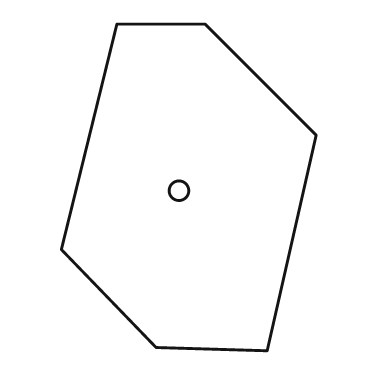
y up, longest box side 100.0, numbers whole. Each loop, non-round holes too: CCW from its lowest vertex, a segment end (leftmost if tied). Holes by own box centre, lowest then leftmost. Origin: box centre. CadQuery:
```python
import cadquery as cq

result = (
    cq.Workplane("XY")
    .moveTo(24.0, -50.0)
    .lineTo(39.0, 16.0)
    .lineTo(5.0, 50.0)
    .lineTo(-22.0, 50.0)
    .lineTo(-39.0, -19.0)
    .lineTo(-10.0, -49.0)
    .close()
    .moveTo(-3.0, -1.0)
    .circle(3.0)
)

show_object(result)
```